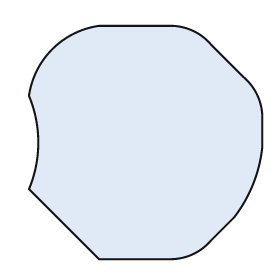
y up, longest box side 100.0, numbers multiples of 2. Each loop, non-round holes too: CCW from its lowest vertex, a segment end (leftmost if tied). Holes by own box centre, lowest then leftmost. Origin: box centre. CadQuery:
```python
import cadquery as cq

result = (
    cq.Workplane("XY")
    .moveTo(-20.0, -50.0)
    .lineTo(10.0, -50.0)
    .threePointArc((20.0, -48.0), (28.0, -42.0))
    .lineTo(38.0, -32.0)
    .threePointArc((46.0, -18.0), (50.0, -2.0))
    .lineTo(50.0, 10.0)
    .threePointArc((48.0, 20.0), (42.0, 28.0))
    .lineTo(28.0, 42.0)
    .threePointArc((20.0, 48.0), (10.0, 50.0))
    .lineTo(-20.0, 50.0)
    .threePointArc((-40.0, 40.0), (-50.0, 20.0))
    .threePointArc((-46.0, 0.0), (-50.0, -20.0))
    .close()
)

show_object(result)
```